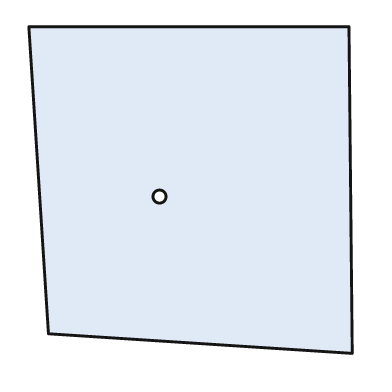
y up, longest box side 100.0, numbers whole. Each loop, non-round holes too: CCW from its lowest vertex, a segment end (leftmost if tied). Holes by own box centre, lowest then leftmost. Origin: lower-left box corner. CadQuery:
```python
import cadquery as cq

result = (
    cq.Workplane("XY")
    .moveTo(99.0, 0.0)
    .lineTo(98.0, 100.0)
    .lineTo(0.0, 100.0)
    .lineTo(6.0, 6.0)
    .close()
    .moveTo(40.0, 48.0)
    .circle(2.0)
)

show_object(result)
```